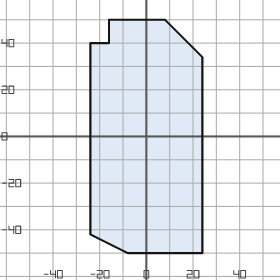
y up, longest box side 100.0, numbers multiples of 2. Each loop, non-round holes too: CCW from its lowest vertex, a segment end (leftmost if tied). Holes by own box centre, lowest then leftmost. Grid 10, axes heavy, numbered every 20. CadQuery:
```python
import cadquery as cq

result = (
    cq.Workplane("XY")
    .moveTo(-8.0, -50.0)
    .lineTo(24.0, -50.0)
    .lineTo(24.0, 34.0)
    .lineTo(8.0, 50.0)
    .lineTo(-16.0, 50.0)
    .lineTo(-16.0, 40.0)
    .lineTo(-24.0, 40.0)
    .lineTo(-24.0, -42.0)
    .close()
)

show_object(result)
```